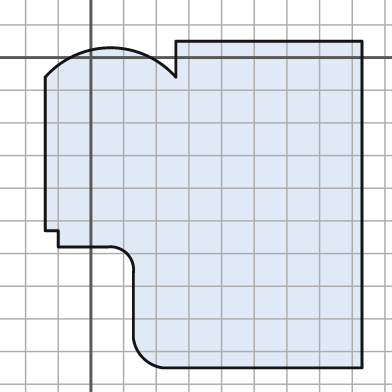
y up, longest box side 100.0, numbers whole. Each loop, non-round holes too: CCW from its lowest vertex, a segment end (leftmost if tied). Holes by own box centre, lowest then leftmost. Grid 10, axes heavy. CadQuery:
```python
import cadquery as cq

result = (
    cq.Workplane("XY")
    .moveTo(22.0, -95.0)
    .lineTo(83.0, -95.0)
    .lineTo(83.0, 5.0)
    .lineTo(26.0, 5.0)
    .lineTo(26.0, -6.0)
    .threePointArc((6.0, 3.0), (-14.0, -6.0))
    .lineTo(-14.0, -53.0)
    .lineTo(-10.0, -53.0)
    .lineTo(-10.0, -58.0)
    .lineTo(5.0, -58.0)
    .threePointArc((11.0, -60.0), (13.0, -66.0))
    .lineTo(13.0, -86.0)
    .threePointArc((16.0, -92.0), (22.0, -95.0))
    .close()
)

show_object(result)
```